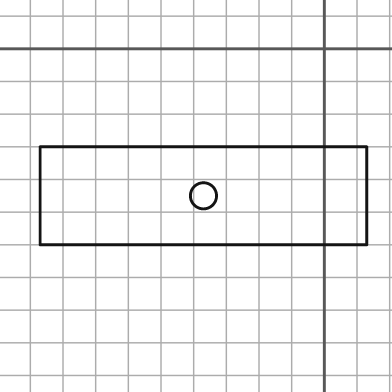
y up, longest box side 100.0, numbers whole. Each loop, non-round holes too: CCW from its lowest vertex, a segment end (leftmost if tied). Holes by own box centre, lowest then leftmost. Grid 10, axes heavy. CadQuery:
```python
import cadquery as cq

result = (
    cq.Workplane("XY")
    .moveTo(-87.0, -60.0)
    .lineTo(13.0, -60.0)
    .lineTo(13.0, -30.0)
    .lineTo(-87.0, -30.0)
    .close()
    .moveTo(-37.0, -45.0)
    .circle(4.0)
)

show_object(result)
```